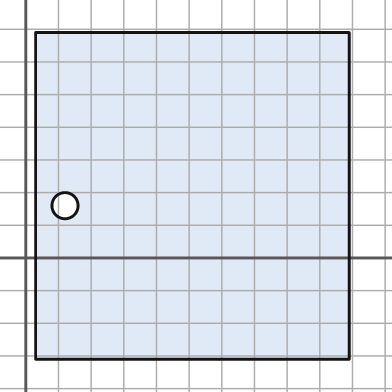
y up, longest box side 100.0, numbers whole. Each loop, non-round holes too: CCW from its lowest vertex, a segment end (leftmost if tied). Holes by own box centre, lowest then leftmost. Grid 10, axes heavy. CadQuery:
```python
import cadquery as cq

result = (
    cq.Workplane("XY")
    .moveTo(3.0, -31.0)
    .lineTo(99.0, -31.0)
    .lineTo(99.0, 69.0)
    .lineTo(3.0, 69.0)
    .close()
    .moveTo(12.0, 16.0)
    .circle(4.0)
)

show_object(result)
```